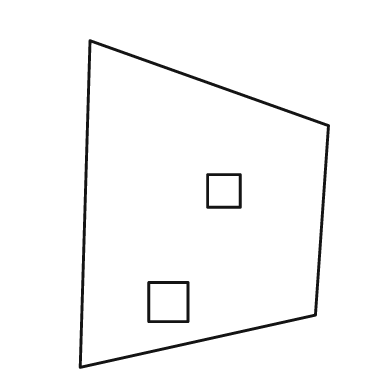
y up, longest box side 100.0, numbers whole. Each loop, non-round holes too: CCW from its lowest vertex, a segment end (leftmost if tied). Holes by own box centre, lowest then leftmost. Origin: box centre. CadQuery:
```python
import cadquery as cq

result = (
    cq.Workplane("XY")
    .moveTo(-38.0, -50.0)
    .lineTo(34.0, -34.0)
    .lineTo(38.0, 24.0)
    .lineTo(-35.0, 50.0)
    .close()
    .moveTo(-17.0, -36.0)
    .lineTo(-5.0, -36.0)
    .lineTo(-5.0, -24.0)
    .lineTo(-17.0, -24.0)
    .close()
    .moveTo(1.0, -1.0)
    .lineTo(11.0, -1.0)
    .lineTo(11.0, 9.0)
    .lineTo(1.0, 9.0)
    .close()
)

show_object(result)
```